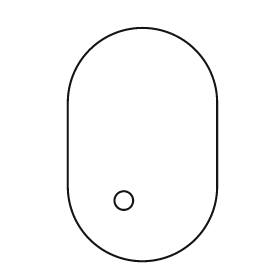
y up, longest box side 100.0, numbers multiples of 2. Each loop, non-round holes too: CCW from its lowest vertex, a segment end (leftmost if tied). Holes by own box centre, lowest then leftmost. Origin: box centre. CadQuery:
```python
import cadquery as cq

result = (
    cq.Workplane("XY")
    .moveTo(-32.0, -18.0)
    .threePointArc((0.0, -50.0), (32.0, -18.0))
    .lineTo(32.0, 18.0)
    .threePointArc((0.0, 50.0), (-32.0, 18.0))
    .close()
    .moveTo(-8.0, -24.0)
    .circle(4.0)
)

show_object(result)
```